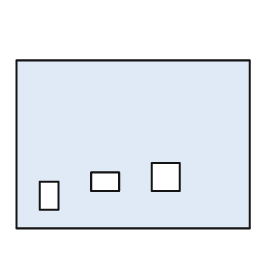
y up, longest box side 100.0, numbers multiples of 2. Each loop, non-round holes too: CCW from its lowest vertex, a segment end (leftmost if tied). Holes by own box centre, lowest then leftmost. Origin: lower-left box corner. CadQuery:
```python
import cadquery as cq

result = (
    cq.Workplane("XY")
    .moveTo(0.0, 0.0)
    .lineTo(100.0, 0.0)
    .lineTo(100.0, 72.0)
    .lineTo(0.0, 72.0)
    .close()
    .moveTo(10.0, 8.0)
    .lineTo(18.0, 8.0)
    .lineTo(18.0, 20.0)
    .lineTo(10.0, 20.0)
    .close()
    .moveTo(32.0, 16.0)
    .lineTo(44.0, 16.0)
    .lineTo(44.0, 24.0)
    .lineTo(32.0, 24.0)
    .close()
    .moveTo(58.0, 16.0)
    .lineTo(70.0, 16.0)
    .lineTo(70.0, 28.0)
    .lineTo(58.0, 28.0)
    .close()
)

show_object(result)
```